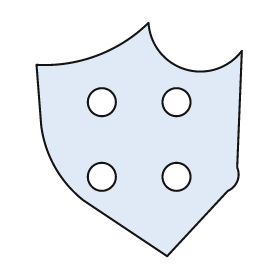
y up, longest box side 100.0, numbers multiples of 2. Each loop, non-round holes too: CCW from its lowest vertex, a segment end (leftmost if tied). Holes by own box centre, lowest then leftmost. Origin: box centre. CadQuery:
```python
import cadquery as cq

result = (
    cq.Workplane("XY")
    .moveTo(12.0, -50.0)
    .lineTo(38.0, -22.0)
    .threePointArc((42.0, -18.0), (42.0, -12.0))
    .lineTo(44.0, 38.0)
    .threePointArc((20.0, 30.0), (4.0, 50.0))
    .threePointArc((-18.0, 36.0), (-44.0, 32.0))
    .lineTo(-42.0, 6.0)
    .threePointArc((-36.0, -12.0), (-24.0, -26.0))
    .close()
    .moveTo(-16.0, -16.0)
    .circle(6.0)
    .moveTo(16.0, -16.0)
    .circle(6.0)
    .moveTo(-16.0, 16.0)
    .circle(6.0)
    .moveTo(16.0, 16.0)
    .circle(6.0)
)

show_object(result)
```